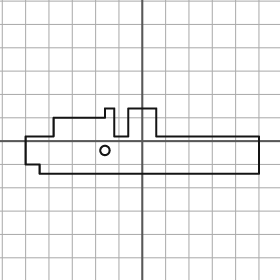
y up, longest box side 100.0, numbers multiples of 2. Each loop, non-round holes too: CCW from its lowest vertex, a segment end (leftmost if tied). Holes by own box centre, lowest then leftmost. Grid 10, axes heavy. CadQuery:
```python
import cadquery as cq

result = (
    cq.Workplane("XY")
    .moveTo(-44.0, -14.0)
    .lineTo(50.0, -14.0)
    .lineTo(50.0, 2.0)
    .lineTo(6.0, 2.0)
    .lineTo(6.0, 14.0)
    .lineTo(-6.0, 14.0)
    .lineTo(-6.0, 2.0)
    .lineTo(-12.0, 2.0)
    .lineTo(-12.0, 14.0)
    .lineTo(-16.0, 14.0)
    .lineTo(-16.0, 10.0)
    .lineTo(-38.0, 10.0)
    .lineTo(-38.0, 2.0)
    .lineTo(-50.0, 2.0)
    .lineTo(-50.0, -10.0)
    .lineTo(-44.0, -10.0)
    .close()
    .moveTo(-16.0, -4.0)
    .circle(2.0)
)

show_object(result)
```